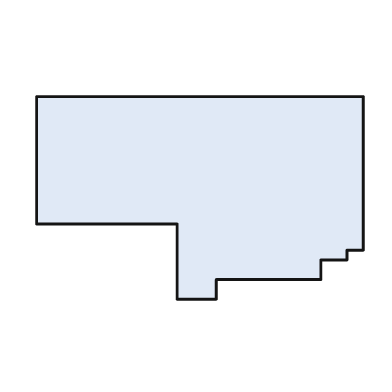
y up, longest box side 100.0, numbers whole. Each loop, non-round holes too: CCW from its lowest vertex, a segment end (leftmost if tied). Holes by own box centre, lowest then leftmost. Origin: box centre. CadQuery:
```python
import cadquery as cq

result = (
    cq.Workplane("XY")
    .moveTo(-7.0, -31.0)
    .lineTo(5.0, -31.0)
    .lineTo(5.0, -25.0)
    .lineTo(37.0, -25.0)
    .lineTo(37.0, -19.0)
    .lineTo(45.0, -19.0)
    .lineTo(45.0, -16.0)
    .lineTo(50.0, -16.0)
    .lineTo(50.0, 31.0)
    .lineTo(-50.0, 31.0)
    .lineTo(-50.0, -8.0)
    .lineTo(-7.0, -8.0)
    .close()
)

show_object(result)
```